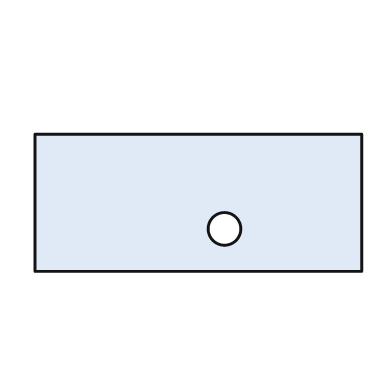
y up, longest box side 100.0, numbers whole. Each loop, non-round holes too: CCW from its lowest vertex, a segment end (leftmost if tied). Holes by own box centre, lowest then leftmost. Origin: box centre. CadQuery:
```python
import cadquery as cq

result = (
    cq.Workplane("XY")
    .moveTo(-50.0, -21.0)
    .lineTo(50.0, -21.0)
    .lineTo(50.0, 21.0)
    .lineTo(-50.0, 21.0)
    .close()
    .moveTo(8.0, -8.0)
    .circle(5.0)
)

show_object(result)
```